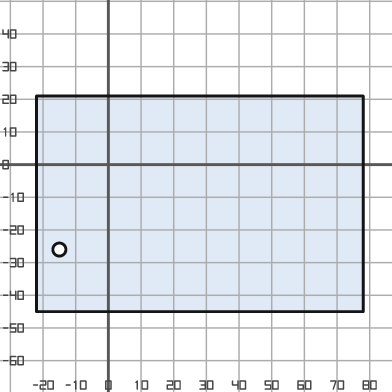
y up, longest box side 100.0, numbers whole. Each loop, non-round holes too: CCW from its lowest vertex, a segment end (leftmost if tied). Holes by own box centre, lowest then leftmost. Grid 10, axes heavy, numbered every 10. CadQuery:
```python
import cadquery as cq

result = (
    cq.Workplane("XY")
    .moveTo(-22.0, -45.0)
    .lineTo(78.0, -45.0)
    .lineTo(78.0, 21.0)
    .lineTo(-22.0, 21.0)
    .close()
    .moveTo(-15.0, -26.0)
    .circle(2.0)
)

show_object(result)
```